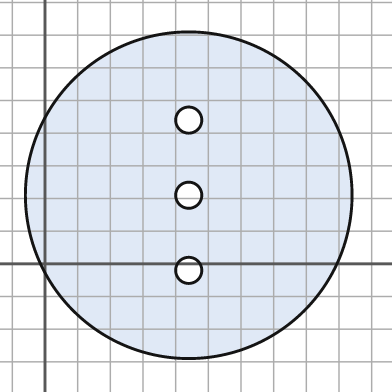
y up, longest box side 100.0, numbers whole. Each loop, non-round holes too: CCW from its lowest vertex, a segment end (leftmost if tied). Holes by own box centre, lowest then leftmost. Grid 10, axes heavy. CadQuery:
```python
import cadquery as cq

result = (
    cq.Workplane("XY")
    .moveTo(44.0, 21.0)
    .circle(50.0)
    .moveTo(44.0, -2.0)
    .circle(4.0)
    .moveTo(44.0, 21.0)
    .circle(4.0)
    .moveTo(44.0, 44.0)
    .circle(4.0)
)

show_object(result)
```